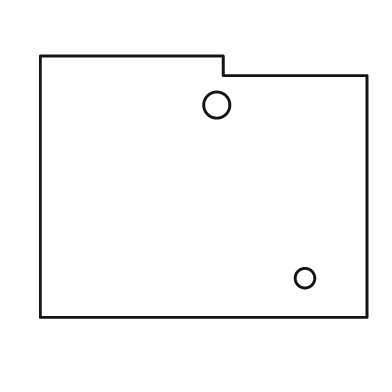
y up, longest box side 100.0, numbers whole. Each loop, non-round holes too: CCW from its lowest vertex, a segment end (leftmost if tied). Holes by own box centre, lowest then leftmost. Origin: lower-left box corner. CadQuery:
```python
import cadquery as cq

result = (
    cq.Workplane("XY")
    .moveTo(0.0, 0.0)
    .lineTo(100.0, 0.0)
    .lineTo(100.0, 74.0)
    .lineTo(56.0, 74.0)
    .lineTo(56.0, 80.0)
    .lineTo(0.0, 80.0)
    .close()
    .moveTo(81.0, 12.0)
    .circle(3.0)
    .moveTo(54.0, 65.0)
    .circle(4.0)
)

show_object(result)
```